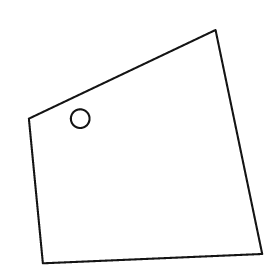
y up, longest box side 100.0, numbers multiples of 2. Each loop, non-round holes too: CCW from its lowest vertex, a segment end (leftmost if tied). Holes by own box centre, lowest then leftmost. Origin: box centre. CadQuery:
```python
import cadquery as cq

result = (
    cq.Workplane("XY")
    .moveTo(-44.0, -50.0)
    .lineTo(50.0, -46.0)
    .lineTo(30.0, 50.0)
    .lineTo(-50.0, 12.0)
    .close()
    .moveTo(-28.0, 12.0)
    .circle(4.0)
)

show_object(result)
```